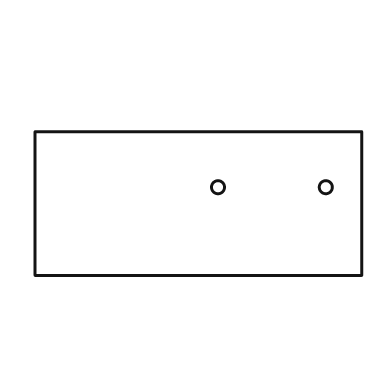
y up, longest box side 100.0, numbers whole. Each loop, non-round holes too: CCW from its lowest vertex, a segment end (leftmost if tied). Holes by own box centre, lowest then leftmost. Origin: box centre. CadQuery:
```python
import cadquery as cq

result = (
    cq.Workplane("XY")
    .moveTo(-50.0, -22.0)
    .lineTo(50.0, -22.0)
    .lineTo(50.0, 22.0)
    .lineTo(-50.0, 22.0)
    .close()
    .moveTo(6.0, 5.0)
    .circle(2.0)
    .moveTo(39.0, 5.0)
    .circle(2.0)
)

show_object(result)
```